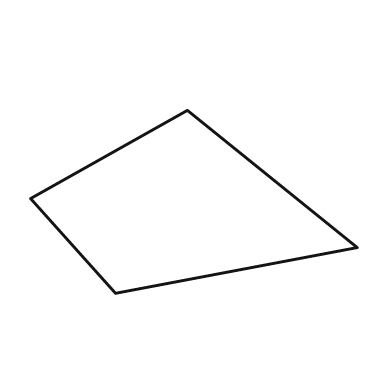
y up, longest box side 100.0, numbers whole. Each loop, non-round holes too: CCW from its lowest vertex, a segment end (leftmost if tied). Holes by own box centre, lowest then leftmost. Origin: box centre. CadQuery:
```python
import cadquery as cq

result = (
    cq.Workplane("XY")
    .moveTo(-24.0, -28.0)
    .lineTo(50.0, -14.0)
    .lineTo(-2.0, 28.0)
    .lineTo(-50.0, 1.0)
    .close()
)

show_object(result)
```